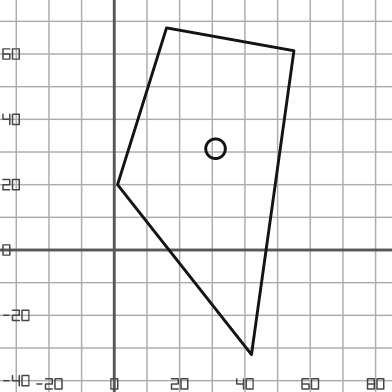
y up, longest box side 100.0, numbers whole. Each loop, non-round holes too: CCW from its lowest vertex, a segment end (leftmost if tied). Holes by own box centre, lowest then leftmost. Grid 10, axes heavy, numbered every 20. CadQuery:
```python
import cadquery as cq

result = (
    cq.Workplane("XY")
    .moveTo(42.0, -32.0)
    .lineTo(55.0, 61.0)
    .lineTo(16.0, 68.0)
    .lineTo(1.0, 20.0)
    .close()
    .moveTo(31.0, 31.0)
    .circle(3.0)
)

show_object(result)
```